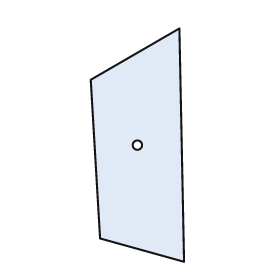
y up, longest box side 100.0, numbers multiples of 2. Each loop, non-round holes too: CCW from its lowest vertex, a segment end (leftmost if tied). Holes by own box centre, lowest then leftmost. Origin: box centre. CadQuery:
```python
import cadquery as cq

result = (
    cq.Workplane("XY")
    .moveTo(20.0, -50.0)
    .lineTo(18.0, 50.0)
    .lineTo(-20.0, 28.0)
    .lineTo(-16.0, -40.0)
    .close()
    .moveTo(0.0, 0.0)
    .circle(2.0)
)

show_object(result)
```